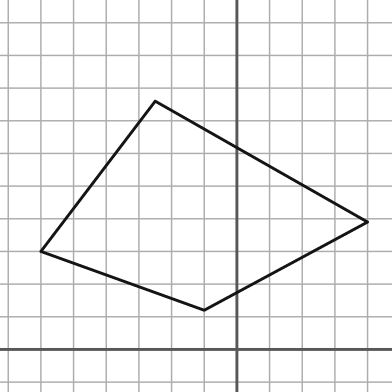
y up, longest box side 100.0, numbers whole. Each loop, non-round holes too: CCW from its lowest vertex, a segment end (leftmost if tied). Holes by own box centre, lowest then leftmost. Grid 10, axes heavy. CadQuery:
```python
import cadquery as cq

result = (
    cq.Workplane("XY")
    .moveTo(-10.0, 12.0)
    .lineTo(40.0, 39.0)
    .lineTo(-25.0, 76.0)
    .lineTo(-60.0, 30.0)
    .close()
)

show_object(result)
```